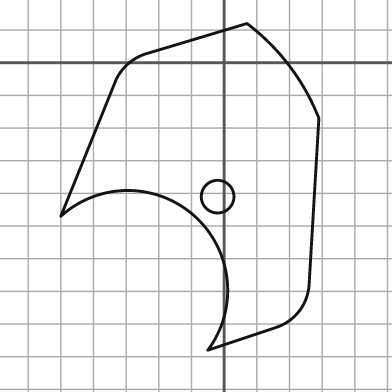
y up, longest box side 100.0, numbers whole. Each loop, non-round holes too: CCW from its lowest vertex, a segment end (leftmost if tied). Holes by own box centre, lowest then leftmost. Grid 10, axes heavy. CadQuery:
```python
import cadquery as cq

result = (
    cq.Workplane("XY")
    .moveTo(-5.0, -88.0)
    .lineTo(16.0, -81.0)
    .threePointArc((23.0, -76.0), (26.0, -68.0))
    .lineTo(29.0, -17.0)
    .threePointArc((20.0, -1.0), (7.0, 12.0))
    .lineTo(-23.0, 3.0)
    .threePointArc((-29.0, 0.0), (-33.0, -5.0))
    .lineTo(-50.0, -47.0)
    .threePointArc((-9.0, -47.0), (-5.0, -88.0))
    .close()
    .moveTo(-2.0, -41.0)
    .circle(5.0)
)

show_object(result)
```